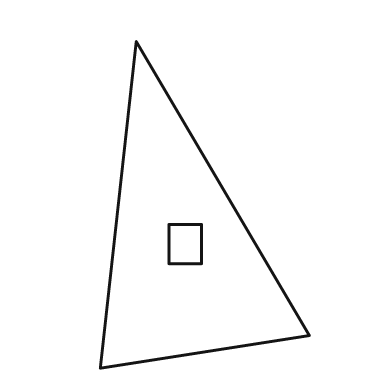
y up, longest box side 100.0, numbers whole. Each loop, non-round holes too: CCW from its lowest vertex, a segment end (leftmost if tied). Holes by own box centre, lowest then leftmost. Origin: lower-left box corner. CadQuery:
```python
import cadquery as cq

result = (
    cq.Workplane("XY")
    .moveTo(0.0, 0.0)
    .lineTo(64.0, 10.0)
    .lineTo(11.0, 100.0)
    .close()
    .moveTo(21.0, 32.0)
    .lineTo(31.0, 32.0)
    .lineTo(31.0, 44.0)
    .lineTo(21.0, 44.0)
    .close()
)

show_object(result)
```